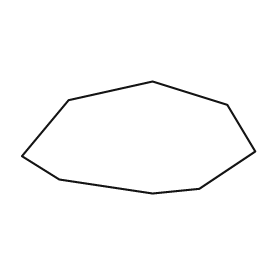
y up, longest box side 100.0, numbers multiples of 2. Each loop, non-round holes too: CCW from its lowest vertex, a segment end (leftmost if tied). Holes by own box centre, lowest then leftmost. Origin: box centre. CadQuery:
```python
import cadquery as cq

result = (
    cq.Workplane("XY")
    .moveTo(6.0, -24.0)
    .lineTo(26.0, -22.0)
    .lineTo(50.0, -6.0)
    .lineTo(38.0, 14.0)
    .lineTo(6.0, 24.0)
    .lineTo(-30.0, 16.0)
    .lineTo(-50.0, -8.0)
    .lineTo(-34.0, -18.0)
    .close()
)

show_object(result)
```